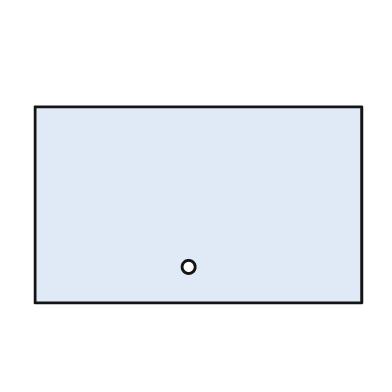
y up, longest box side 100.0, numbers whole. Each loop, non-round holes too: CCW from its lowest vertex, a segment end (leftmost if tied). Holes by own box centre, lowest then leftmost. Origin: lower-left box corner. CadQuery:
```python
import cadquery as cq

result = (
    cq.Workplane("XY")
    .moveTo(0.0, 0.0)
    .lineTo(100.0, 0.0)
    .lineTo(100.0, 60.0)
    .lineTo(0.0, 60.0)
    .close()
    .moveTo(47.0, 11.0)
    .circle(2.0)
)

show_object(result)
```